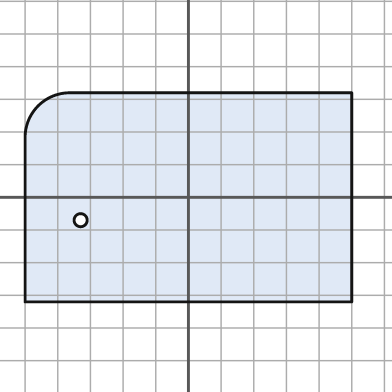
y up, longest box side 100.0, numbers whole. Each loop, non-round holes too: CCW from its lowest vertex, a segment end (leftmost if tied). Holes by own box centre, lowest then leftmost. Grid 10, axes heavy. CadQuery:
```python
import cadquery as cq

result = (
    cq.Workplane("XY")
    .moveTo(-50.0, -32.0)
    .lineTo(50.0, -32.0)
    .lineTo(50.0, 32.0)
    .lineTo(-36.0, 32.0)
    .threePointArc((-46.0, 28.0), (-50.0, 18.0))
    .close()
    .moveTo(-33.0, -7.0)
    .circle(2.0)
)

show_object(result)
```